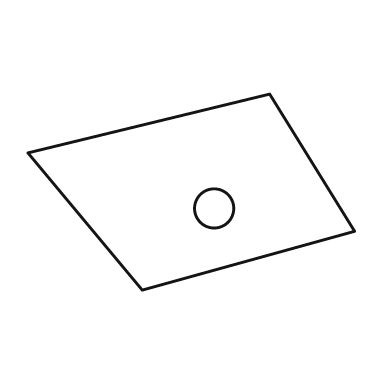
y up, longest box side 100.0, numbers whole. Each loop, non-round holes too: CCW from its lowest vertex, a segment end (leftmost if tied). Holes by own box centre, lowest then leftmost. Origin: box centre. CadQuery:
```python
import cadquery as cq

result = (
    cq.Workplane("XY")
    .moveTo(-15.0, -30.0)
    .lineTo(50.0, -12.0)
    .lineTo(24.0, 30.0)
    .lineTo(-50.0, 12.0)
    .close()
    .moveTo(7.0, -5.0)
    .circle(6.0)
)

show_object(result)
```